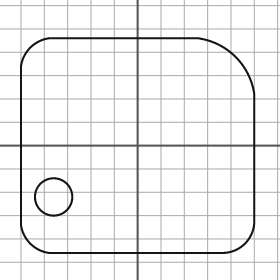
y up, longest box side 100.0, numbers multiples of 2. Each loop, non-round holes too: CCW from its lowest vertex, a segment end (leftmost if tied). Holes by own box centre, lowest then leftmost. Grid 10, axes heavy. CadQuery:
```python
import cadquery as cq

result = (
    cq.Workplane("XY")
    .moveTo(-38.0, -46.0)
    .lineTo(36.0, -46.0)
    .threePointArc((46.0, -42.0), (50.0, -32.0))
    .lineTo(50.0, 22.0)
    .threePointArc((42.0, 38.0), (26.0, 46.0))
    .lineTo(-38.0, 46.0)
    .threePointArc((-46.0, 42.0), (-50.0, 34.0))
    .lineTo(-50.0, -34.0)
    .threePointArc((-46.0, -42.0), (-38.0, -46.0))
    .close()
    .moveTo(-36.0, -22.0)
    .circle(8.0)
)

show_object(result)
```